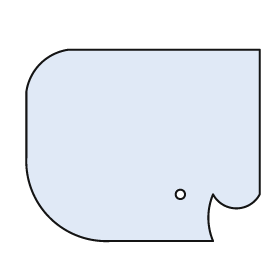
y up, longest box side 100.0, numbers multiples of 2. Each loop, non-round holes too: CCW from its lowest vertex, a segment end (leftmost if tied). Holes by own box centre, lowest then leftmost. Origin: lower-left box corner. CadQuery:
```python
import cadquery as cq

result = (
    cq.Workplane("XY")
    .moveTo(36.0, 0.0)
    .lineTo(80.0, 0.0)
    .threePointArc((78.0, 10.0), (80.0, 20.0))
    .threePointArc((90.0, 14.0), (100.0, 20.0))
    .lineTo(100.0, 82.0)
    .lineTo(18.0, 82.0)
    .threePointArc((6.0, 76.0), (0.0, 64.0))
    .lineTo(0.0, 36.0)
    .threePointArc((10.0, 10.0), (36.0, 0.0))
    .close()
    .moveTo(66.0, 20.0)
    .circle(2.0)
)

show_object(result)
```